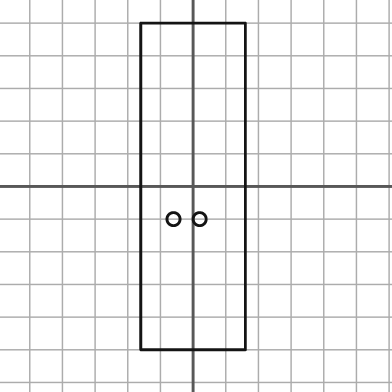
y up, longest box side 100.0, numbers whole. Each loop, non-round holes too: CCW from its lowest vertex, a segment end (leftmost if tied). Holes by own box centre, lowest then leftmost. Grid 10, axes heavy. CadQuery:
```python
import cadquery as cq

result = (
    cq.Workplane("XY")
    .moveTo(-16.0, -50.0)
    .lineTo(16.0, -50.0)
    .lineTo(16.0, 50.0)
    .lineTo(-16.0, 50.0)
    .close()
    .moveTo(-6.0, -10.0)
    .circle(2.0)
    .moveTo(2.0, -10.0)
    .circle(2.0)
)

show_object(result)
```